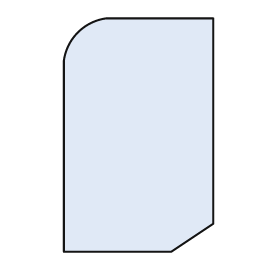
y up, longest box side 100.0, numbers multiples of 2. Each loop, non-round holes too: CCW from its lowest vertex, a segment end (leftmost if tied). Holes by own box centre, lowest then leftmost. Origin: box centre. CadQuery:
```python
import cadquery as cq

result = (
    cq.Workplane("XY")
    .moveTo(-32.0, -50.0)
    .lineTo(14.0, -50.0)
    .lineTo(32.0, -38.0)
    .lineTo(32.0, 50.0)
    .lineTo(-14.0, 50.0)
    .threePointArc((-26.0, 44.0), (-32.0, 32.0))
    .close()
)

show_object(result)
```